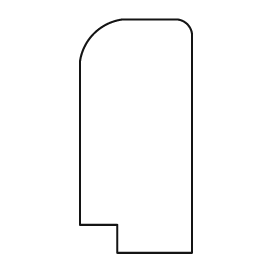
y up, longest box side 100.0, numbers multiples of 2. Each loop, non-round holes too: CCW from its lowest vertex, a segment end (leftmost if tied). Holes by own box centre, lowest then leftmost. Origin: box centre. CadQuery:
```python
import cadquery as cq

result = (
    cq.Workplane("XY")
    .moveTo(-8.0, -50.0)
    .lineTo(24.0, -50.0)
    .lineTo(24.0, 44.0)
    .threePointArc((22.0, 48.0), (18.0, 50.0))
    .lineTo(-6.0, 50.0)
    .threePointArc((-18.0, 44.0), (-24.0, 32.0))
    .lineTo(-24.0, -38.0)
    .lineTo(-8.0, -38.0)
    .close()
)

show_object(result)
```